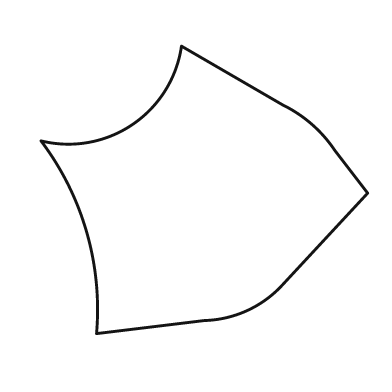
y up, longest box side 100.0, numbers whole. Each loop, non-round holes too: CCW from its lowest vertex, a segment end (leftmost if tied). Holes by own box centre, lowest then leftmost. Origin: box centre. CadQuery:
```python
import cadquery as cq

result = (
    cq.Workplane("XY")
    .moveTo(-33.0, -44.0)
    .lineTo(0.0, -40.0)
    .threePointArc((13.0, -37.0), (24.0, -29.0))
    .lineTo(50.0, -1.0)
    .lineTo(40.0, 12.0)
    .threePointArc((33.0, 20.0), (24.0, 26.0))
    .lineTo(-7.0, 44.0)
    .threePointArc((-22.0, 20.0), (-50.0, 15.0))
    .threePointArc((-36.0, -13.0), (-33.0, -44.0))
    .close()
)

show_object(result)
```